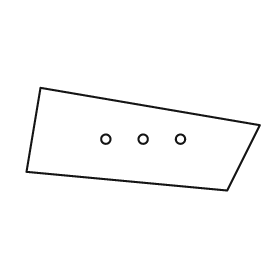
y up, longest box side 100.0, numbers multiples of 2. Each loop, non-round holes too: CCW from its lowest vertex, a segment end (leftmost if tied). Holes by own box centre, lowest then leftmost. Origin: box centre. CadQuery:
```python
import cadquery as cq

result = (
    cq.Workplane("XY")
    .moveTo(36.0, -22.0)
    .lineTo(50.0, 6.0)
    .lineTo(-44.0, 22.0)
    .lineTo(-50.0, -14.0)
    .close()
    .moveTo(-16.0, 0.0)
    .circle(2.0)
    .moveTo(0.0, 0.0)
    .circle(2.0)
    .moveTo(16.0, 0.0)
    .circle(2.0)
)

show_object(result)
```